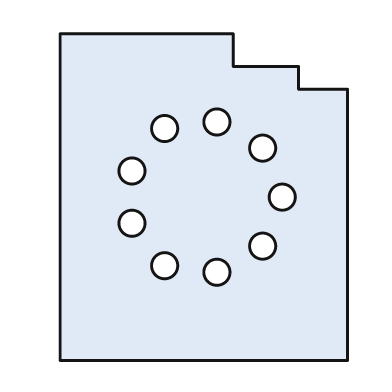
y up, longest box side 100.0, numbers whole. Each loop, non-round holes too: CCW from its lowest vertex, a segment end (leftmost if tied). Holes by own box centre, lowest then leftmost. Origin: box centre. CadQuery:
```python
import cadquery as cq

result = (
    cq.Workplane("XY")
    .moveTo(-44.0, -50.0)
    .lineTo(44.0, -50.0)
    .lineTo(44.0, 33.0)
    .lineTo(29.0, 33.0)
    .lineTo(29.0, 40.0)
    .lineTo(9.0, 40.0)
    .lineTo(9.0, 50.0)
    .lineTo(-44.0, 50.0)
    .close()
    .moveTo(4.0, -23.0)
    .circle(4.0)
    .moveTo(-12.0, -21.0)
    .circle(4.0)
    .moveTo(18.0, -15.0)
    .circle(4.0)
    .moveTo(-22.0, -8.0)
    .circle(4.0)
    .moveTo(24.0, 0.0)
    .circle(4.0)
    .moveTo(-22.0, 8.0)
    .circle(4.0)
    .moveTo(18.0, 15.0)
    .circle(4.0)
    .moveTo(-12.0, 21.0)
    .circle(4.0)
    .moveTo(4.0, 23.0)
    .circle(4.0)
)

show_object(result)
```